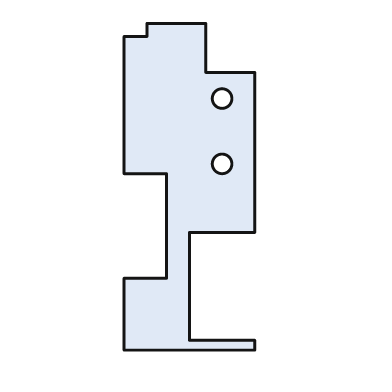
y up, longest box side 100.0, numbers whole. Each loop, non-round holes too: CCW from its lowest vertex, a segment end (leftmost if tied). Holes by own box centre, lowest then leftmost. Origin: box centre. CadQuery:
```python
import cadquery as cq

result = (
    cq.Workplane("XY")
    .moveTo(-20.0, -50.0)
    .lineTo(20.0, -50.0)
    .lineTo(20.0, -47.0)
    .lineTo(0.0, -47.0)
    .lineTo(0.0, -14.0)
    .lineTo(20.0, -14.0)
    .lineTo(20.0, 35.0)
    .lineTo(5.0, 35.0)
    .lineTo(5.0, 50.0)
    .lineTo(-13.0, 50.0)
    .lineTo(-13.0, 46.0)
    .lineTo(-20.0, 46.0)
    .lineTo(-20.0, 4.0)
    .lineTo(-7.0, 4.0)
    .lineTo(-7.0, -28.0)
    .lineTo(-20.0, -28.0)
    .close()
    .moveTo(10.0, 7.0)
    .circle(3.0)
    .moveTo(10.0, 27.0)
    .circle(3.0)
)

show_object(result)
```